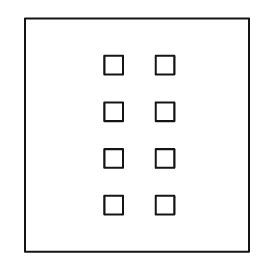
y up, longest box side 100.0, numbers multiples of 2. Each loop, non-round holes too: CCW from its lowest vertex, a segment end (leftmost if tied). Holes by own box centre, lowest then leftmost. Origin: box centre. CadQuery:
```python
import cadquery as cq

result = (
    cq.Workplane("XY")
    .moveTo(-48.0, -50.0)
    .lineTo(48.0, -50.0)
    .lineTo(48.0, 50.0)
    .lineTo(-48.0, 50.0)
    .close()
    .moveTo(-14.0, -34.0)
    .lineTo(-6.0, -34.0)
    .lineTo(-6.0, -26.0)
    .lineTo(-14.0, -26.0)
    .close()
    .moveTo(8.0, -34.0)
    .lineTo(16.0, -34.0)
    .lineTo(16.0, -26.0)
    .lineTo(8.0, -26.0)
    .close()
    .moveTo(-14.0, -14.0)
    .lineTo(-6.0, -14.0)
    .lineTo(-6.0, -6.0)
    .lineTo(-14.0, -6.0)
    .close()
    .moveTo(8.0, -14.0)
    .lineTo(16.0, -14.0)
    .lineTo(16.0, -6.0)
    .lineTo(8.0, -6.0)
    .close()
    .moveTo(-14.0, 6.0)
    .lineTo(-6.0, 6.0)
    .lineTo(-6.0, 14.0)
    .lineTo(-14.0, 14.0)
    .close()
    .moveTo(8.0, 6.0)
    .lineTo(16.0, 6.0)
    .lineTo(16.0, 14.0)
    .lineTo(8.0, 14.0)
    .close()
    .moveTo(-14.0, 26.0)
    .lineTo(-6.0, 26.0)
    .lineTo(-6.0, 34.0)
    .lineTo(-14.0, 34.0)
    .close()
    .moveTo(8.0, 26.0)
    .lineTo(16.0, 26.0)
    .lineTo(16.0, 34.0)
    .lineTo(8.0, 34.0)
    .close()
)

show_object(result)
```